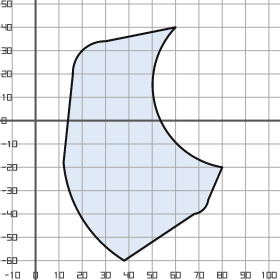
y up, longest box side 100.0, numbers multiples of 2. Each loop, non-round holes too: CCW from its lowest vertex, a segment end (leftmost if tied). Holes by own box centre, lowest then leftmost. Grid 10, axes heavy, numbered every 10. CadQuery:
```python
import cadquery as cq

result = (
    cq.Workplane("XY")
    .moveTo(38.0, -60.0)
    .lineTo(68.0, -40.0)
    .threePointArc((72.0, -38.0), (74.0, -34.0))
    .lineTo(80.0, -20.0)
    .threePointArc((52.0, 4.0), (60.0, 40.0))
    .lineTo(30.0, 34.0)
    .threePointArc((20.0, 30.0), (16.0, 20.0))
    .lineTo(12.0, -18.0)
    .threePointArc((20.0, -42.0), (38.0, -60.0))
    .close()
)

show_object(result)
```